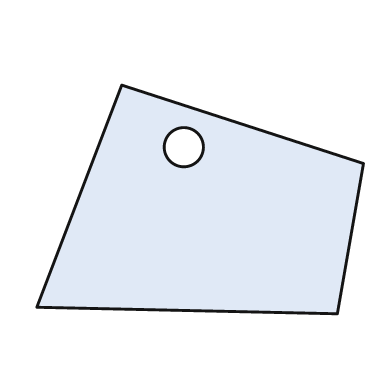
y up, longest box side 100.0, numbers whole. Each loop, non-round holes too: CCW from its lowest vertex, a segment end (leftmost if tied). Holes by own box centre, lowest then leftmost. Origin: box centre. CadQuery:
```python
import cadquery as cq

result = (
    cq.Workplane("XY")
    .moveTo(42.0, -35.0)
    .lineTo(50.0, 11.0)
    .lineTo(-24.0, 35.0)
    .lineTo(-50.0, -33.0)
    .close()
    .moveTo(-5.0, 16.0)
    .circle(6.0)
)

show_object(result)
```